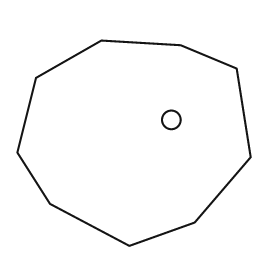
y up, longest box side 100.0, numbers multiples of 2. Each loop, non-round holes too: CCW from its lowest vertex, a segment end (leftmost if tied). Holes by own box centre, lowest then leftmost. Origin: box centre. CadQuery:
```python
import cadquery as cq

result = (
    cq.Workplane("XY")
    .moveTo(-2.0, -44.0)
    .lineTo(26.0, -34.0)
    .lineTo(50.0, -6.0)
    .lineTo(44.0, 32.0)
    .lineTo(20.0, 42.0)
    .lineTo(-14.0, 44.0)
    .lineTo(-42.0, 28.0)
    .lineTo(-50.0, -4.0)
    .lineTo(-36.0, -26.0)
    .close()
    .moveTo(16.0, 10.0)
    .circle(4.0)
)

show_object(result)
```